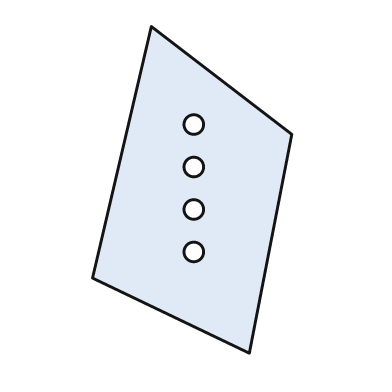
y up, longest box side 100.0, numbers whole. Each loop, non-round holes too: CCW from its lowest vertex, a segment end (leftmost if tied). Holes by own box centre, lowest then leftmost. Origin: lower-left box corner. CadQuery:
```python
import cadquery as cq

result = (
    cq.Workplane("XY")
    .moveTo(48.0, 0.0)
    .lineTo(61.0, 67.0)
    .lineTo(18.0, 100.0)
    .lineTo(0.0, 23.0)
    .close()
    .moveTo(31.0, 31.0)
    .circle(3.0)
    .moveTo(31.0, 44.0)
    .circle(3.0)
    .moveTo(31.0, 57.0)
    .circle(3.0)
    .moveTo(31.0, 70.0)
    .circle(3.0)
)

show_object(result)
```